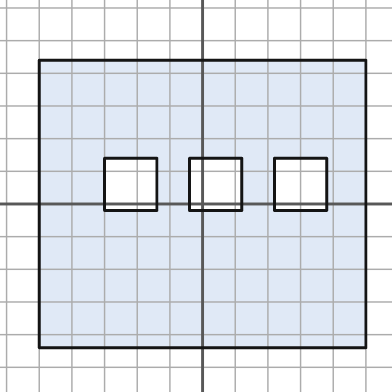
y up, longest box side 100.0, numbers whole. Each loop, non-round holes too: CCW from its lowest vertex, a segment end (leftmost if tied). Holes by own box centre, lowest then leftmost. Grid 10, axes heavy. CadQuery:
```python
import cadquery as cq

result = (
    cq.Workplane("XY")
    .moveTo(-50.0, -44.0)
    .lineTo(50.0, -44.0)
    .lineTo(50.0, 44.0)
    .lineTo(-50.0, 44.0)
    .close()
    .moveTo(-30.0, -2.0)
    .lineTo(-14.0, -2.0)
    .lineTo(-14.0, 14.0)
    .lineTo(-30.0, 14.0)
    .close()
    .moveTo(-4.0, -2.0)
    .lineTo(12.0, -2.0)
    .lineTo(12.0, 14.0)
    .lineTo(-4.0, 14.0)
    .close()
    .moveTo(22.0, -2.0)
    .lineTo(38.0, -2.0)
    .lineTo(38.0, 14.0)
    .lineTo(22.0, 14.0)
    .close()
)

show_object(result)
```